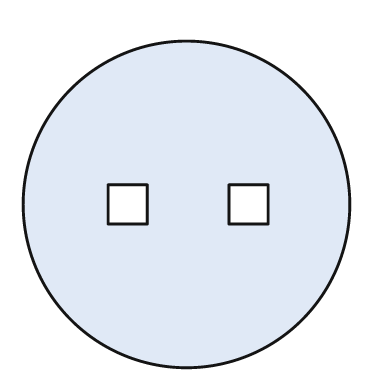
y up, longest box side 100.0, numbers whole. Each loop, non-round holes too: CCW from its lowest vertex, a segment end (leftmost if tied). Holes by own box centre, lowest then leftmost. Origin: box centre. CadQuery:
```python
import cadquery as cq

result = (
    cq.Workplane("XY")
    .moveTo(0.0, 0.0)
    .circle(50.0)
    .moveTo(-24.0, -6.0)
    .lineTo(-12.0, -6.0)
    .lineTo(-12.0, 6.0)
    .lineTo(-24.0, 6.0)
    .close()
    .moveTo(13.0, -6.0)
    .lineTo(25.0, -6.0)
    .lineTo(25.0, 6.0)
    .lineTo(13.0, 6.0)
    .close()
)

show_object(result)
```